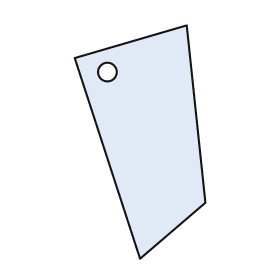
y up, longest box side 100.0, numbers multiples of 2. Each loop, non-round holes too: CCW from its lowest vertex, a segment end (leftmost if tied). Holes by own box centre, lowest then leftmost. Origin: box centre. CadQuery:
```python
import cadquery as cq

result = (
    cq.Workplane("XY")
    .moveTo(0.0, -50.0)
    .lineTo(28.0, -26.0)
    .lineTo(20.0, 50.0)
    .lineTo(-28.0, 36.0)
    .close()
    .moveTo(-14.0, 30.0)
    .circle(4.0)
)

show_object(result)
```